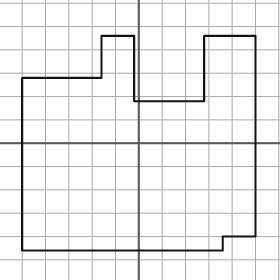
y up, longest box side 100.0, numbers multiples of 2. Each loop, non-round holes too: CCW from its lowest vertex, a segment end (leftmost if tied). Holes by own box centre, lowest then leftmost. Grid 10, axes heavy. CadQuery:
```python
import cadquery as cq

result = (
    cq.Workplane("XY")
    .moveTo(-50.0, -46.0)
    .lineTo(36.0, -46.0)
    .lineTo(36.0, -40.0)
    .lineTo(50.0, -40.0)
    .lineTo(50.0, 46.0)
    .lineTo(28.0, 46.0)
    .lineTo(28.0, 18.0)
    .lineTo(-2.0, 18.0)
    .lineTo(-2.0, 46.0)
    .lineTo(-16.0, 46.0)
    .lineTo(-16.0, 28.0)
    .lineTo(-50.0, 28.0)
    .close()
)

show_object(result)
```